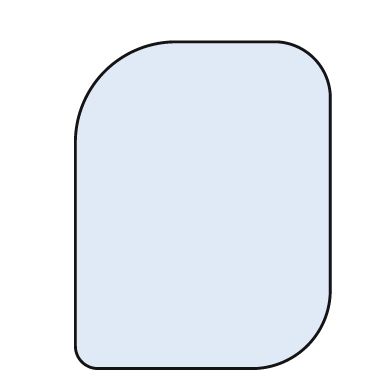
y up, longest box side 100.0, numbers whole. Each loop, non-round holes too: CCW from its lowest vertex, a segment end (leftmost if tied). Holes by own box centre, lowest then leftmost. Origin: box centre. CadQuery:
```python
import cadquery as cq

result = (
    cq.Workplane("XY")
    .moveTo(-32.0, -50.0)
    .lineTo(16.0, -50.0)
    .threePointArc((32.0, -43.0), (39.0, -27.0))
    .lineTo(39.0, 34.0)
    .threePointArc((34.0, 45.0), (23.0, 50.0))
    .lineTo(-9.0, 50.0)
    .threePointArc((-30.0, 41.0), (-39.0, 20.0))
    .lineTo(-39.0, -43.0)
    .threePointArc((-37.0, -48.0), (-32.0, -50.0))
    .close()
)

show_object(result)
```